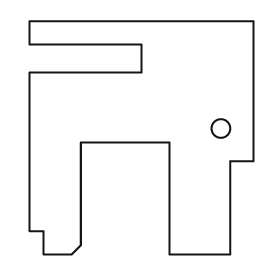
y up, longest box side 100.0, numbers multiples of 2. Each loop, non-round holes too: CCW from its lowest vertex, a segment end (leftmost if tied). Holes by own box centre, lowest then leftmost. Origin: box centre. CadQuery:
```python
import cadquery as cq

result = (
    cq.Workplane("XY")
    .moveTo(-42.0, -50.0)
    .lineTo(-30.0, -50.0)
    .lineTo(-26.0, -46.0)
    .lineTo(-26.0, -2.0)
    .lineTo(12.0, -2.0)
    .lineTo(12.0, -50.0)
    .lineTo(38.0, -50.0)
    .lineTo(38.0, -10.0)
    .lineTo(48.0, -10.0)
    .lineTo(48.0, 50.0)
    .lineTo(-48.0, 50.0)
    .lineTo(-48.0, 40.0)
    .lineTo(0.0, 40.0)
    .lineTo(0.0, 28.0)
    .lineTo(-48.0, 28.0)
    .lineTo(-48.0, -40.0)
    .lineTo(-42.0, -40.0)
    .close()
    .moveTo(34.0, 4.0)
    .circle(4.0)
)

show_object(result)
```